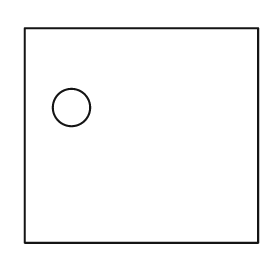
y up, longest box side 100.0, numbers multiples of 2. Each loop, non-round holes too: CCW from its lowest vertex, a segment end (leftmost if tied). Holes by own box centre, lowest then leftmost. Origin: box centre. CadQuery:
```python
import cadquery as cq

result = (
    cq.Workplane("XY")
    .moveTo(-50.0, -46.0)
    .lineTo(50.0, -46.0)
    .lineTo(50.0, 46.0)
    .lineTo(-50.0, 46.0)
    .close()
    .moveTo(-30.0, 12.0)
    .circle(8.0)
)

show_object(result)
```